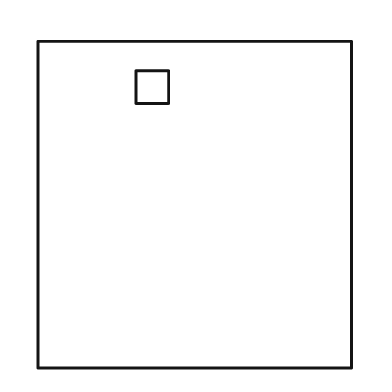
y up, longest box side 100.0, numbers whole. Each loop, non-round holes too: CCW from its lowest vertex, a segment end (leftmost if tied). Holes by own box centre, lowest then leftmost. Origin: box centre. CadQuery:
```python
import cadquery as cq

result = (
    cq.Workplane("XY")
    .moveTo(-48.0, -50.0)
    .lineTo(48.0, -50.0)
    .lineTo(48.0, 50.0)
    .lineTo(-48.0, 50.0)
    .close()
    .moveTo(-18.0, 31.0)
    .lineTo(-8.0, 31.0)
    .lineTo(-8.0, 41.0)
    .lineTo(-18.0, 41.0)
    .close()
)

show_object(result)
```